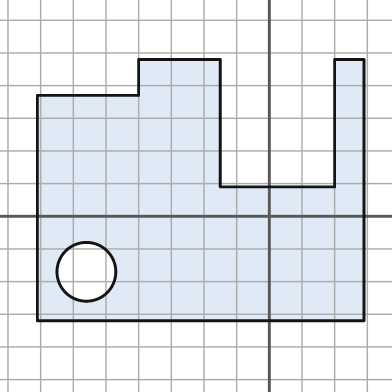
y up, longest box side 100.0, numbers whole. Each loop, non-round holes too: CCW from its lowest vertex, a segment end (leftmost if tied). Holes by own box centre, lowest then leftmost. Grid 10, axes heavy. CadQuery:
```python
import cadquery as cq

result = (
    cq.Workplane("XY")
    .moveTo(-71.0, -32.0)
    .lineTo(29.0, -32.0)
    .lineTo(29.0, 48.0)
    .lineTo(20.0, 48.0)
    .lineTo(20.0, 9.0)
    .lineTo(-15.0, 9.0)
    .lineTo(-15.0, 48.0)
    .lineTo(-40.0, 48.0)
    .lineTo(-40.0, 37.0)
    .lineTo(-71.0, 37.0)
    .close()
    .moveTo(-56.0, -17.0)
    .circle(9.0)
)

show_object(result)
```